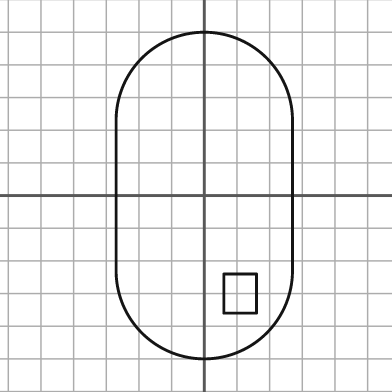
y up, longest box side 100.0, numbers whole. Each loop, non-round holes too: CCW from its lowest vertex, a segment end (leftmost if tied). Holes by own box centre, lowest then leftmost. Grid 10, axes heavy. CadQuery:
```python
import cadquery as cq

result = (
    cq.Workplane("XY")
    .moveTo(-27.0, -23.0)
    .threePointArc((0.0, -50.0), (27.0, -23.0))
    .lineTo(27.0, 23.0)
    .threePointArc((0.0, 50.0), (-27.0, 23.0))
    .close()
    .moveTo(6.0, -36.0)
    .lineTo(16.0, -36.0)
    .lineTo(16.0, -24.0)
    .lineTo(6.0, -24.0)
    .close()
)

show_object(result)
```